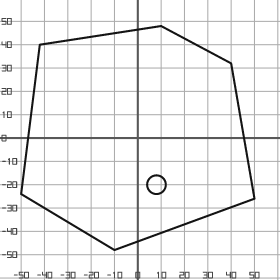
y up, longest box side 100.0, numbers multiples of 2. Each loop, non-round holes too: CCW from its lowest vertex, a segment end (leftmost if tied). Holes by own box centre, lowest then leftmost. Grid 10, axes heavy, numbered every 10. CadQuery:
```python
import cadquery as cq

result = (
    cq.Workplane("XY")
    .moveTo(-10.0, -48.0)
    .lineTo(50.0, -26.0)
    .lineTo(40.0, 32.0)
    .lineTo(10.0, 48.0)
    .lineTo(-42.0, 40.0)
    .lineTo(-50.0, -24.0)
    .close()
    .moveTo(8.0, -20.0)
    .circle(4.0)
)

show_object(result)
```